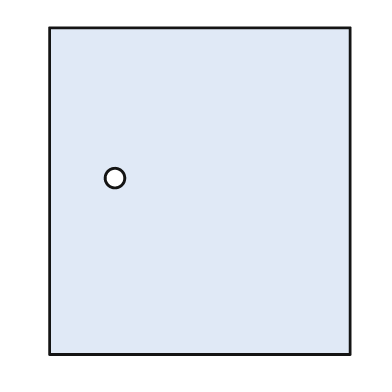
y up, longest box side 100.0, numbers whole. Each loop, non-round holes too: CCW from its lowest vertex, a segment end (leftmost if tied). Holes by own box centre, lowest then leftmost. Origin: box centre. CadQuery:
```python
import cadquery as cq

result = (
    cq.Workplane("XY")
    .moveTo(-46.0, -50.0)
    .lineTo(46.0, -50.0)
    .lineTo(46.0, 50.0)
    .lineTo(-46.0, 50.0)
    .close()
    .moveTo(-26.0, 4.0)
    .circle(3.0)
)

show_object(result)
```